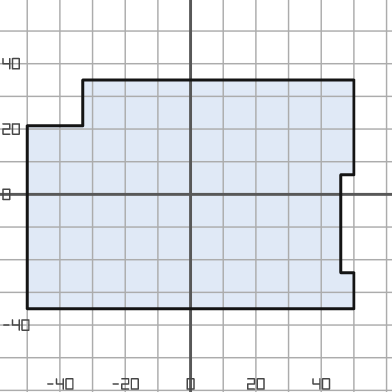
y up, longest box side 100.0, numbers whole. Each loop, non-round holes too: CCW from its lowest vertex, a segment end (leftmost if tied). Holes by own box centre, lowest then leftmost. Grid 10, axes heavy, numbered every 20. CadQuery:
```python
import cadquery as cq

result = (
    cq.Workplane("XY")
    .moveTo(-50.0, -35.0)
    .lineTo(50.0, -35.0)
    .lineTo(50.0, -24.0)
    .lineTo(46.0, -24.0)
    .lineTo(46.0, 6.0)
    .lineTo(50.0, 6.0)
    .lineTo(50.0, 35.0)
    .lineTo(-33.0, 35.0)
    .lineTo(-33.0, 21.0)
    .lineTo(-50.0, 21.0)
    .close()
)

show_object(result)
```